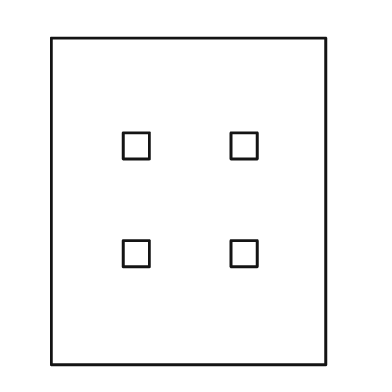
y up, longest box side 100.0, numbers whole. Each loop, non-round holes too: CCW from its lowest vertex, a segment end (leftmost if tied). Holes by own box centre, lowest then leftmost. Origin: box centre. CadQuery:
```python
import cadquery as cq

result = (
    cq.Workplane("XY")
    .moveTo(-42.0, -50.0)
    .lineTo(42.0, -50.0)
    .lineTo(42.0, 50.0)
    .lineTo(-42.0, 50.0)
    .close()
    .moveTo(-20.0, -20.0)
    .lineTo(-12.0, -20.0)
    .lineTo(-12.0, -12.0)
    .lineTo(-20.0, -12.0)
    .close()
    .moveTo(13.0, -20.0)
    .lineTo(21.0, -20.0)
    .lineTo(21.0, -12.0)
    .lineTo(13.0, -12.0)
    .close()
    .moveTo(-20.0, 13.0)
    .lineTo(-12.0, 13.0)
    .lineTo(-12.0, 21.0)
    .lineTo(-20.0, 21.0)
    .close()
    .moveTo(13.0, 13.0)
    .lineTo(21.0, 13.0)
    .lineTo(21.0, 21.0)
    .lineTo(13.0, 21.0)
    .close()
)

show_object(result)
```